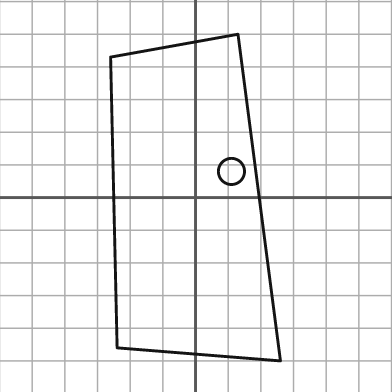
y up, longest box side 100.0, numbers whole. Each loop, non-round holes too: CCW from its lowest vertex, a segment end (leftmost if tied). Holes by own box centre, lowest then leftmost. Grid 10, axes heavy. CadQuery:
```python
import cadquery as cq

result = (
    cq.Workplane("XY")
    .moveTo(26.0, -50.0)
    .lineTo(13.0, 50.0)
    .lineTo(-26.0, 43.0)
    .lineTo(-24.0, -46.0)
    .close()
    .moveTo(11.0, 8.0)
    .circle(4.0)
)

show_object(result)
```